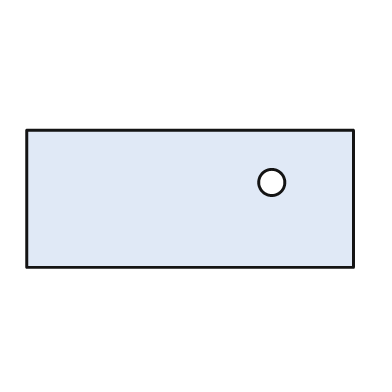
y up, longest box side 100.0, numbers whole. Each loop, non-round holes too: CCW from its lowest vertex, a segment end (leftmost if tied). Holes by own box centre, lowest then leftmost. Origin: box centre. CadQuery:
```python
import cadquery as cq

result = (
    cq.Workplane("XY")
    .moveTo(-50.0, -21.0)
    .lineTo(50.0, -21.0)
    .lineTo(50.0, 21.0)
    .lineTo(-50.0, 21.0)
    .close()
    .moveTo(25.0, 5.0)
    .circle(4.0)
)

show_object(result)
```